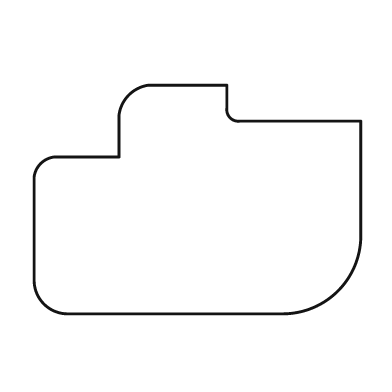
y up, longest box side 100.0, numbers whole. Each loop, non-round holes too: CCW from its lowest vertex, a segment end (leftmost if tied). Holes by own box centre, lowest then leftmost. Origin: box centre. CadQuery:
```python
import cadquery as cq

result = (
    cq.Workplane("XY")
    .moveTo(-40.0, -35.0)
    .lineTo(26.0, -35.0)
    .threePointArc((43.0, -28.0), (50.0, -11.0))
    .lineTo(50.0, 24.0)
    .lineTo(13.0, 24.0)
    .threePointArc((10.0, 25.0), (9.0, 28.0))
    .lineTo(9.0, 35.0)
    .lineTo(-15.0, 35.0)
    .threePointArc((-21.0, 32.0), (-24.0, 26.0))
    .lineTo(-24.0, 13.0)
    .lineTo(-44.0, 13.0)
    .threePointArc((-48.0, 11.0), (-50.0, 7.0))
    .lineTo(-50.0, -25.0)
    .threePointArc((-47.0, -32.0), (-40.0, -35.0))
    .close()
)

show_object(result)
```